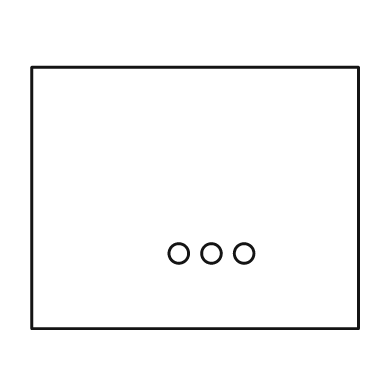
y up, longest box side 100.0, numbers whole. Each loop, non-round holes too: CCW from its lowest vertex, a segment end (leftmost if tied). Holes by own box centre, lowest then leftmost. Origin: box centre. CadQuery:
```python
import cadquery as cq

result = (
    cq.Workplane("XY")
    .moveTo(-50.0, -40.0)
    .lineTo(50.0, -40.0)
    .lineTo(50.0, 40.0)
    .lineTo(-50.0, 40.0)
    .close()
    .moveTo(-5.0, -17.0)
    .circle(3.0)
    .moveTo(5.0, -17.0)
    .circle(3.0)
    .moveTo(15.0, -17.0)
    .circle(3.0)
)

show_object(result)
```